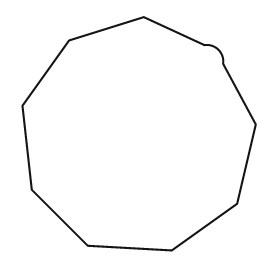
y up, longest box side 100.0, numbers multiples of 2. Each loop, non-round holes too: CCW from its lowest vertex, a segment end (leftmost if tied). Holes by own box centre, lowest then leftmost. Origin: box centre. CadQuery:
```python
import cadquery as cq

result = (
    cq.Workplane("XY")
    .moveTo(14.0, -50.0)
    .lineTo(42.0, -30.0)
    .lineTo(50.0, 4.0)
    .lineTo(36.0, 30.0)
    .threePointArc((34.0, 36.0), (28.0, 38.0))
    .lineTo(2.0, 50.0)
    .lineTo(-30.0, 40.0)
    .lineTo(-50.0, 12.0)
    .lineTo(-46.0, -24.0)
    .lineTo(-22.0, -48.0)
    .close()
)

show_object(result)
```